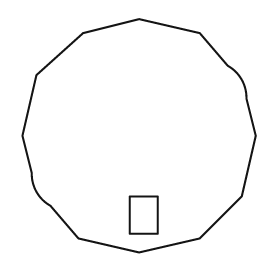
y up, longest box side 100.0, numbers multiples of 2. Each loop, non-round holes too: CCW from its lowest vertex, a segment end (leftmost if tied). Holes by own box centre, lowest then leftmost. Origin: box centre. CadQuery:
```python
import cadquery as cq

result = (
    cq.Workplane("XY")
    .moveTo(0.0, -50.0)
    .lineTo(26.0, -44.0)
    .lineTo(44.0, -26.0)
    .lineTo(50.0, 0.0)
    .lineTo(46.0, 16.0)
    .threePointArc((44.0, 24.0), (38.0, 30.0))
    .lineTo(26.0, 44.0)
    .lineTo(0.0, 50.0)
    .lineTo(-24.0, 44.0)
    .lineTo(-44.0, 26.0)
    .lineTo(-50.0, 0.0)
    .lineTo(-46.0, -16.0)
    .threePointArc((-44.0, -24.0), (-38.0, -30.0))
    .lineTo(-26.0, -44.0)
    .close()
    .moveTo(-4.0, -42.0)
    .lineTo(8.0, -42.0)
    .lineTo(8.0, -26.0)
    .lineTo(-4.0, -26.0)
    .close()
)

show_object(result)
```